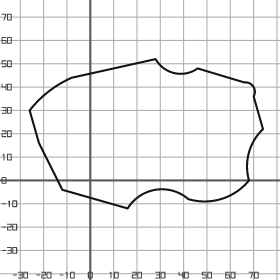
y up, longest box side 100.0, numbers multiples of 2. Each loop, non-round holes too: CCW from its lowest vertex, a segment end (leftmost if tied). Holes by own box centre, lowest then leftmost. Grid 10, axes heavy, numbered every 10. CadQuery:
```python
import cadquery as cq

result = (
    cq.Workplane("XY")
    .moveTo(16.0, -12.0)
    .threePointArc((28.0, -4.0), (42.0, -8.0))
    .threePointArc((56.0, -8.0), (68.0, 0.0))
    .threePointArc((68.0, 12.0), (74.0, 22.0))
    .lineTo(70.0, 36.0)
    .threePointArc((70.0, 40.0), (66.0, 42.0))
    .lineTo(46.0, 48.0)
    .threePointArc((36.0, 46.0), (28.0, 52.0))
    .lineTo(-8.0, 44.0)
    .threePointArc((-18.0, 38.0), (-26.0, 30.0))
    .lineTo(-22.0, 16.0)
    .lineTo(-12.0, -4.0)
    .close()
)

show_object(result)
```